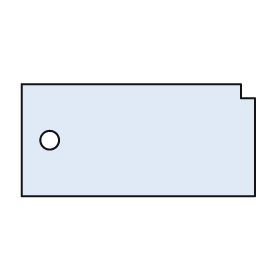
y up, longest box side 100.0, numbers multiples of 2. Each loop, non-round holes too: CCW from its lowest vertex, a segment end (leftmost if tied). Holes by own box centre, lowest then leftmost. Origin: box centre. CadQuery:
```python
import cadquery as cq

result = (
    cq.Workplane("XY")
    .moveTo(-50.0, -24.0)
    .lineTo(50.0, -24.0)
    .lineTo(50.0, 18.0)
    .lineTo(44.0, 18.0)
    .lineTo(44.0, 24.0)
    .lineTo(-50.0, 24.0)
    .close()
    .moveTo(-38.0, 0.0)
    .circle(4.0)
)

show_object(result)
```